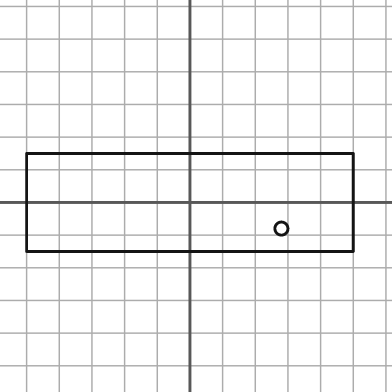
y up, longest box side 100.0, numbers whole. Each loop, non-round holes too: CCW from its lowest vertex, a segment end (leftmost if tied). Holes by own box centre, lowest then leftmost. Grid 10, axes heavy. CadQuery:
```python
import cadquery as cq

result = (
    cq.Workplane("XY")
    .moveTo(-50.0, -15.0)
    .lineTo(50.0, -15.0)
    .lineTo(50.0, 15.0)
    .lineTo(-50.0, 15.0)
    .close()
    .moveTo(28.0, -8.0)
    .circle(2.0)
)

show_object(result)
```